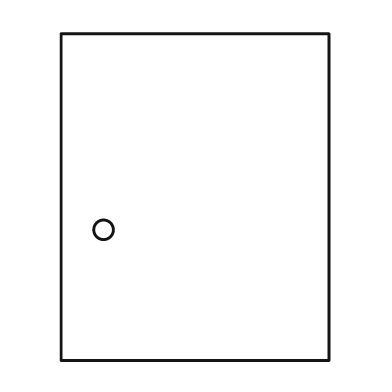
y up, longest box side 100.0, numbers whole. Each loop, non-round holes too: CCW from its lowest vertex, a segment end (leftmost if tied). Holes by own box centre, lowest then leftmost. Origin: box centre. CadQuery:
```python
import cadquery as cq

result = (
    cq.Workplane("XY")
    .moveTo(-41.0, -50.0)
    .lineTo(41.0, -50.0)
    .lineTo(41.0, 50.0)
    .lineTo(-41.0, 50.0)
    .close()
    .moveTo(-28.0, -10.0)
    .circle(3.0)
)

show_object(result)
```